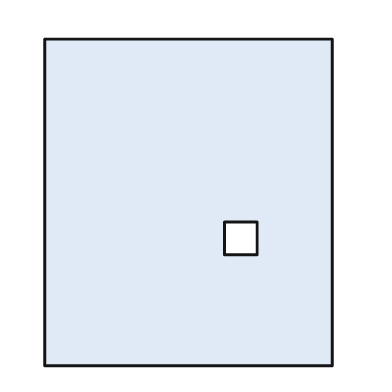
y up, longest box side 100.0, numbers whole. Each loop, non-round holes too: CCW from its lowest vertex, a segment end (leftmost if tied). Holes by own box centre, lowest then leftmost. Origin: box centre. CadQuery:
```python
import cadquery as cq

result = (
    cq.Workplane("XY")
    .moveTo(-44.0, -50.0)
    .lineTo(44.0, -50.0)
    .lineTo(44.0, 50.0)
    .lineTo(-44.0, 50.0)
    .close()
    .moveTo(11.0, -16.0)
    .lineTo(21.0, -16.0)
    .lineTo(21.0, -6.0)
    .lineTo(11.0, -6.0)
    .close()
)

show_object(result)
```